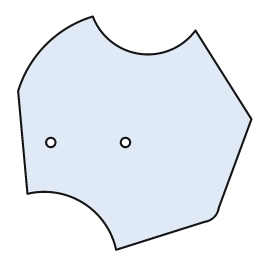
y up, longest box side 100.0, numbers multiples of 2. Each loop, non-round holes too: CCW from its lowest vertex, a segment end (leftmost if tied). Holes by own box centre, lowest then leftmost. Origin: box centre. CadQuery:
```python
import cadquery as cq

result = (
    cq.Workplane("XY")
    .moveTo(-8.0, -50.0)
    .lineTo(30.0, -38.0)
    .threePointArc((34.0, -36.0), (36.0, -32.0))
    .lineTo(50.0, 6.0)
    .lineTo(26.0, 44.0)
    .threePointArc((2.0, 34.0), (-18.0, 50.0))
    .threePointArc((-38.0, 38.0), (-50.0, 18.0))
    .lineTo(-46.0, -26.0)
    .threePointArc((-22.0, -30.0), (-8.0, -50.0))
    .close()
    .moveTo(-36.0, -4.0)
    .circle(2.0)
    .moveTo(-4.0, -4.0)
    .circle(2.0)
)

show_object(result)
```